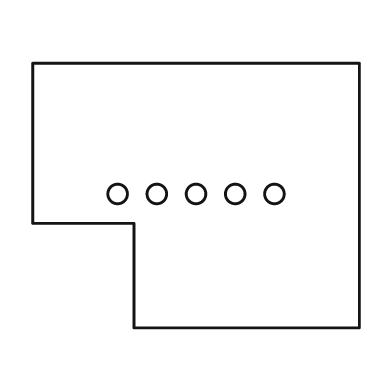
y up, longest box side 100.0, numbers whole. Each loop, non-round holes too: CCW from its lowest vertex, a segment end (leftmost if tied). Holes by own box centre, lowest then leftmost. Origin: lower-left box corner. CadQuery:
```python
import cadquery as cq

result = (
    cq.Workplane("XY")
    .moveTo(31.0, 0.0)
    .lineTo(100.0, 0.0)
    .lineTo(100.0, 81.0)
    .lineTo(0.0, 81.0)
    .lineTo(0.0, 32.0)
    .lineTo(31.0, 32.0)
    .close()
    .moveTo(26.0, 41.0)
    .circle(3.0)
    .moveTo(38.0, 41.0)
    .circle(3.0)
    .moveTo(50.0, 41.0)
    .circle(3.0)
    .moveTo(62.0, 41.0)
    .circle(3.0)
    .moveTo(74.0, 41.0)
    .circle(3.0)
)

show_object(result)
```